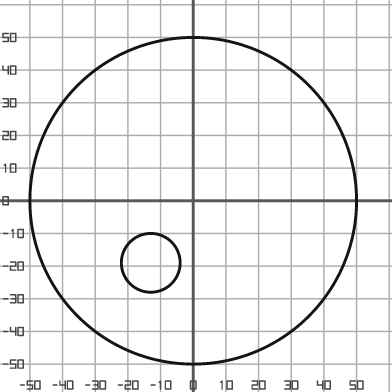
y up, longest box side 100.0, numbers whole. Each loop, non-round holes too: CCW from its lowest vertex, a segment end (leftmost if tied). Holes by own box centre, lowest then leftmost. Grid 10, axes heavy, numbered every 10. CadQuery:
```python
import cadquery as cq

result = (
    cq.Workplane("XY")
    .moveTo(0.0, 0.0)
    .circle(50.0)
    .moveTo(-13.0, -19.0)
    .circle(9.0)
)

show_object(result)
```